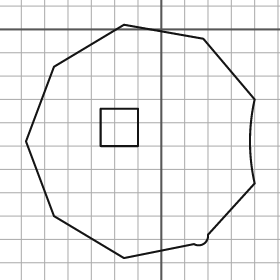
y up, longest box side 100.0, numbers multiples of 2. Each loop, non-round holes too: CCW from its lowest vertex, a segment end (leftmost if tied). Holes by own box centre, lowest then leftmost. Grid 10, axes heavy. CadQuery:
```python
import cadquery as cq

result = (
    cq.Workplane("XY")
    .moveTo(-16.0, -98.0)
    .lineTo(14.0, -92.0)
    .threePointArc((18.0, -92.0), (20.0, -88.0))
    .lineTo(40.0, -66.0)
    .threePointArc((38.0, -48.0), (40.0, -30.0))
    .lineTo(18.0, -4.0)
    .lineTo(-16.0, 2.0)
    .lineTo(-46.0, -16.0)
    .lineTo(-58.0, -48.0)
    .lineTo(-46.0, -80.0)
    .close()
    .moveTo(-26.0, -50.0)
    .lineTo(-10.0, -50.0)
    .lineTo(-10.0, -34.0)
    .lineTo(-26.0, -34.0)
    .close()
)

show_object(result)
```